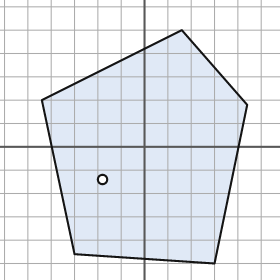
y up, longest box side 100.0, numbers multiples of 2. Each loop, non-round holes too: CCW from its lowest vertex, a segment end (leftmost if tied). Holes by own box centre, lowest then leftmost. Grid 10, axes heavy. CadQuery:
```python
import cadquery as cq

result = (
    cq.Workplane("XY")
    .moveTo(30.0, -50.0)
    .lineTo(44.0, 18.0)
    .lineTo(16.0, 50.0)
    .lineTo(-44.0, 20.0)
    .lineTo(-30.0, -46.0)
    .close()
    .moveTo(-18.0, -14.0)
    .circle(2.0)
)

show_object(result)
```